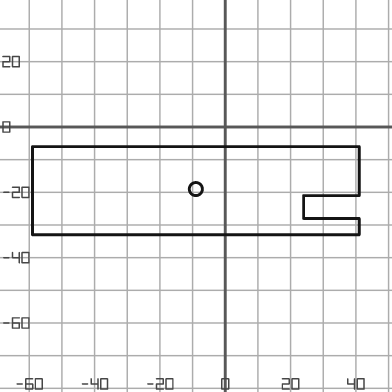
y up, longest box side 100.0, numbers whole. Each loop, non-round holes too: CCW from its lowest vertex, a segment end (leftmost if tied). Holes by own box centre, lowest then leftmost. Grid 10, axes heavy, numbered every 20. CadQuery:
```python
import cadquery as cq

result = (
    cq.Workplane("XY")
    .moveTo(-59.0, -33.0)
    .lineTo(41.0, -33.0)
    .lineTo(41.0, -28.0)
    .lineTo(24.0, -28.0)
    .lineTo(24.0, -21.0)
    .lineTo(41.0, -21.0)
    .lineTo(41.0, -6.0)
    .lineTo(-59.0, -6.0)
    .close()
    .moveTo(-9.0, -19.0)
    .circle(2.0)
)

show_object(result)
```